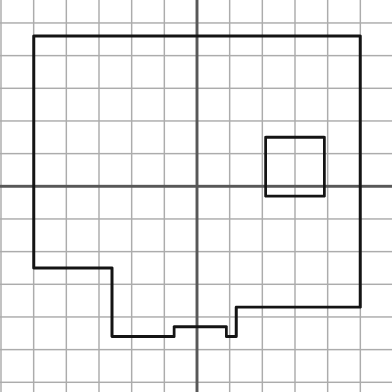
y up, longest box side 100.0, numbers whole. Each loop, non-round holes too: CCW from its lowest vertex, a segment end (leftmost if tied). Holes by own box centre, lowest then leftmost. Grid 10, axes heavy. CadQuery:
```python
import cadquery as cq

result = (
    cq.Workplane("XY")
    .moveTo(-26.0, -46.0)
    .lineTo(-7.0, -46.0)
    .lineTo(-7.0, -43.0)
    .lineTo(9.0, -43.0)
    .lineTo(9.0, -46.0)
    .lineTo(12.0, -46.0)
    .lineTo(12.0, -37.0)
    .lineTo(50.0, -37.0)
    .lineTo(50.0, 46.0)
    .lineTo(-50.0, 46.0)
    .lineTo(-50.0, -25.0)
    .lineTo(-26.0, -25.0)
    .close()
    .moveTo(21.0, -3.0)
    .lineTo(39.0, -3.0)
    .lineTo(39.0, 15.0)
    .lineTo(21.0, 15.0)
    .close()
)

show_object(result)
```